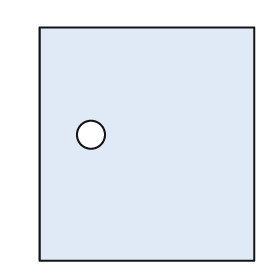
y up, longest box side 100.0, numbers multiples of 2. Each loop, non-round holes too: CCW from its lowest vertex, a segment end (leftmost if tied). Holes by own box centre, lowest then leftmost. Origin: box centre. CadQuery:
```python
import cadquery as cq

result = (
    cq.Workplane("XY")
    .moveTo(-46.0, -50.0)
    .lineTo(46.0, -50.0)
    .lineTo(46.0, 50.0)
    .lineTo(-46.0, 50.0)
    .close()
    .moveTo(-24.0, 4.0)
    .circle(6.0)
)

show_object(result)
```